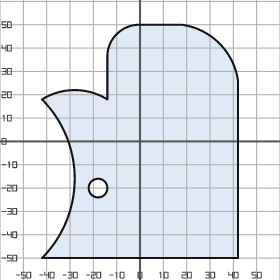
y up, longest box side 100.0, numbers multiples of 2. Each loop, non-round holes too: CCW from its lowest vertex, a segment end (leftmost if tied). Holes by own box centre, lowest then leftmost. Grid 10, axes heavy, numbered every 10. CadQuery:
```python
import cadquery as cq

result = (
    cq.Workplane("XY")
    .moveTo(-42.0, -50.0)
    .lineTo(42.0, -50.0)
    .lineTo(42.0, 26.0)
    .threePointArc((34.0, 42.0), (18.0, 50.0))
    .lineTo(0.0, 50.0)
    .threePointArc((-10.0, 46.0), (-14.0, 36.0))
    .lineTo(-14.0, 18.0)
    .threePointArc((-28.0, 22.0), (-42.0, 18.0))
    .threePointArc((-28.0, -16.0), (-42.0, -50.0))
    .close()
    .moveTo(-18.0, -20.0)
    .circle(4.0)
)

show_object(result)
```